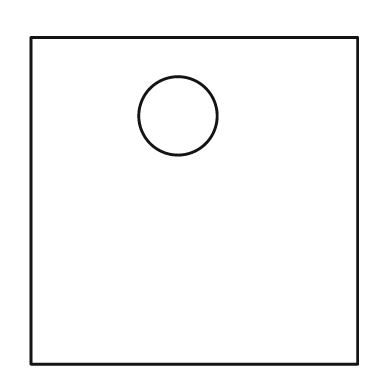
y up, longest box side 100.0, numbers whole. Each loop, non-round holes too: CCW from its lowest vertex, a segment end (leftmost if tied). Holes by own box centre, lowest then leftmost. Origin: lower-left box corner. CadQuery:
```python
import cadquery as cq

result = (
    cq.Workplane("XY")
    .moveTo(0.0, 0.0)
    .lineTo(100.0, 0.0)
    .lineTo(100.0, 100.0)
    .lineTo(0.0, 100.0)
    .close()
    .moveTo(45.0, 76.0)
    .circle(12.0)
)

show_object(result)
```